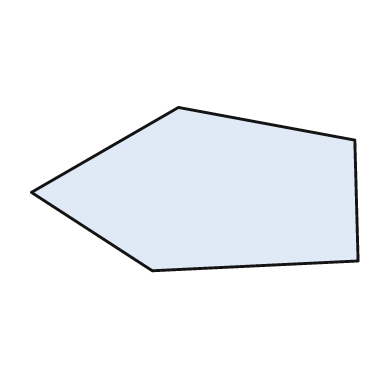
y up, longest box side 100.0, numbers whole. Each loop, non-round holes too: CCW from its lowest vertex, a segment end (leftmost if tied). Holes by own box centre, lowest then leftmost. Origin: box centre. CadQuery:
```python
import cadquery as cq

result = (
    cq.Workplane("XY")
    .moveTo(-13.0, -25.0)
    .lineTo(50.0, -22.0)
    .lineTo(49.0, 15.0)
    .lineTo(-5.0, 25.0)
    .lineTo(-50.0, -1.0)
    .close()
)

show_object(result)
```